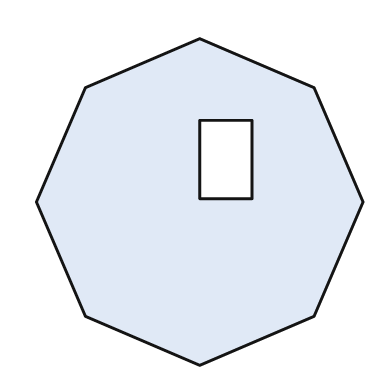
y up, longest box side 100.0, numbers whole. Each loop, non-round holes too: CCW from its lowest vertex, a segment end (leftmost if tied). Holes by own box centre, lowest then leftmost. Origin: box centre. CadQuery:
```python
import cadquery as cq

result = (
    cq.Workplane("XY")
    .moveTo(0.0, -50.0)
    .lineTo(35.0, -35.0)
    .lineTo(50.0, 0.0)
    .lineTo(35.0, 35.0)
    .lineTo(0.0, 50.0)
    .lineTo(-35.0, 35.0)
    .lineTo(-50.0, 0.0)
    .lineTo(-35.0, -35.0)
    .close()
    .moveTo(0.0, 1.0)
    .lineTo(16.0, 1.0)
    .lineTo(16.0, 25.0)
    .lineTo(0.0, 25.0)
    .close()
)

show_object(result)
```